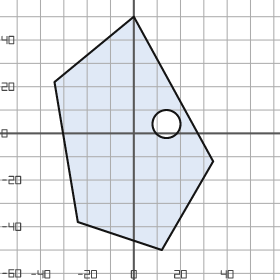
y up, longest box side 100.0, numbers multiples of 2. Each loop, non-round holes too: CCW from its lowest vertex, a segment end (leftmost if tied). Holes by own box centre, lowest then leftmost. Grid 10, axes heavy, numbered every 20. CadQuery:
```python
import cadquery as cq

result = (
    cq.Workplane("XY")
    .moveTo(12.0, -50.0)
    .lineTo(34.0, -12.0)
    .lineTo(0.0, 50.0)
    .lineTo(-34.0, 22.0)
    .lineTo(-24.0, -38.0)
    .close()
    .moveTo(14.0, 4.0)
    .circle(6.0)
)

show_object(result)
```